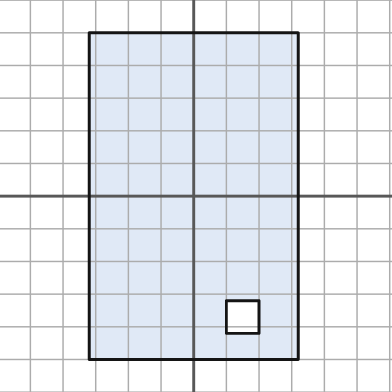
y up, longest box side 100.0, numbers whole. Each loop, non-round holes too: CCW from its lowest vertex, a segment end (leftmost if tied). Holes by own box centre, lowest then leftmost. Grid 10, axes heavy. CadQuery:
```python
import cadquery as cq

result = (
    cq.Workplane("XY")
    .moveTo(-32.0, -50.0)
    .lineTo(32.0, -50.0)
    .lineTo(32.0, 50.0)
    .lineTo(-32.0, 50.0)
    .close()
    .moveTo(10.0, -42.0)
    .lineTo(20.0, -42.0)
    .lineTo(20.0, -32.0)
    .lineTo(10.0, -32.0)
    .close()
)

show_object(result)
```